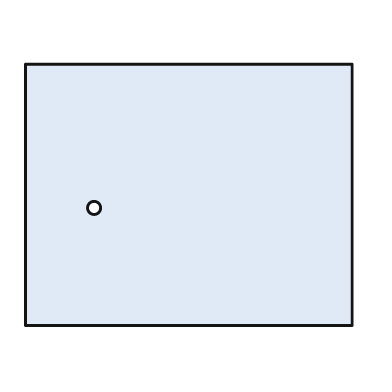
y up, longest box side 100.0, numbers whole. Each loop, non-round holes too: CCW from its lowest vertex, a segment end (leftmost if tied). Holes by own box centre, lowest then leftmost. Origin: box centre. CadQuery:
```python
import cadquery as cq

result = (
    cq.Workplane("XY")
    .moveTo(-50.0, -40.0)
    .lineTo(50.0, -40.0)
    .lineTo(50.0, 40.0)
    .lineTo(-50.0, 40.0)
    .close()
    .moveTo(-29.0, -4.0)
    .circle(2.0)
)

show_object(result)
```